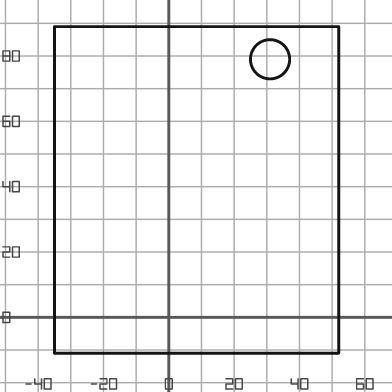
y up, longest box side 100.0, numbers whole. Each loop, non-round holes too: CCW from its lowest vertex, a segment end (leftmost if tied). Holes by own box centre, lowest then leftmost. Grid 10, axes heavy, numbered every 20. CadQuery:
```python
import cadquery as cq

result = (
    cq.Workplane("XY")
    .moveTo(-35.0, -11.0)
    .lineTo(52.0, -11.0)
    .lineTo(52.0, 89.0)
    .lineTo(-35.0, 89.0)
    .close()
    .moveTo(31.0, 79.0)
    .circle(6.0)
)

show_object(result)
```